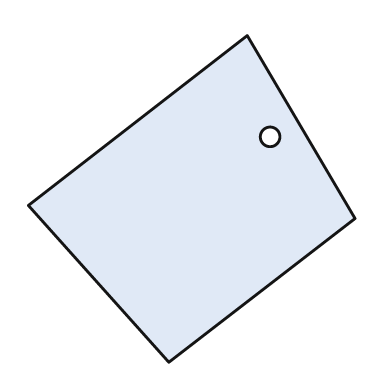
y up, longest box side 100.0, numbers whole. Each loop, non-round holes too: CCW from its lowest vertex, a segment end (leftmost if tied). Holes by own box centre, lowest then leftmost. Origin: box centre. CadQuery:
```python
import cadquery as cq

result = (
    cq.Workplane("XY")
    .moveTo(-7.0, -50.0)
    .lineTo(50.0, -6.0)
    .lineTo(17.0, 50.0)
    .lineTo(-50.0, -2.0)
    .close()
    .moveTo(24.0, 19.0)
    .circle(3.0)
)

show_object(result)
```